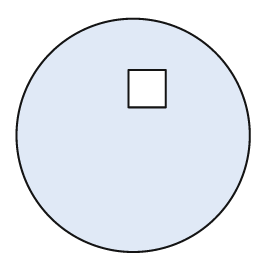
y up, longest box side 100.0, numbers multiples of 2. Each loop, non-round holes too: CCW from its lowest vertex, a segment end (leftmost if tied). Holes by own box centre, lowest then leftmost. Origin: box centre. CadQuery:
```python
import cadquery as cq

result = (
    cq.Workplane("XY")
    .moveTo(0.0, 0.0)
    .circle(50.0)
    .moveTo(-2.0, 12.0)
    .lineTo(14.0, 12.0)
    .lineTo(14.0, 28.0)
    .lineTo(-2.0, 28.0)
    .close()
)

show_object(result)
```